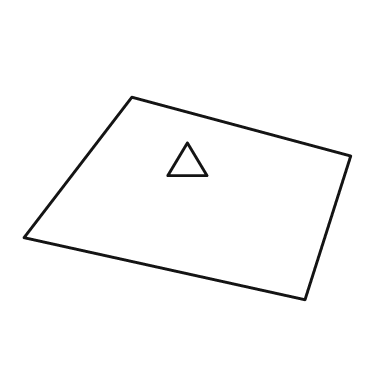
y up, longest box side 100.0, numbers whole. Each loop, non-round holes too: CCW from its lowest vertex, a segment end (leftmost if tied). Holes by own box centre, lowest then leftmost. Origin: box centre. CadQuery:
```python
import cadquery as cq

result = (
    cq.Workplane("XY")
    .moveTo(36.0, -31.0)
    .lineTo(50.0, 13.0)
    .lineTo(-17.0, 31.0)
    .lineTo(-50.0, -12.0)
    .close()
    .moveTo(-6.0, 7.0)
    .lineTo(6.0, 7.0)
    .lineTo(0.0, 17.0)
    .close()
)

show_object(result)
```